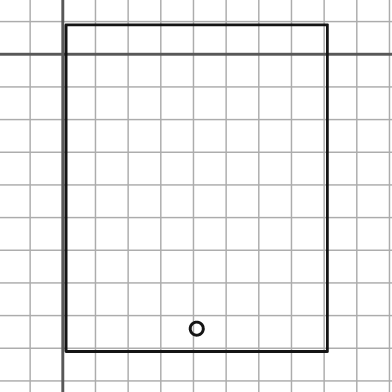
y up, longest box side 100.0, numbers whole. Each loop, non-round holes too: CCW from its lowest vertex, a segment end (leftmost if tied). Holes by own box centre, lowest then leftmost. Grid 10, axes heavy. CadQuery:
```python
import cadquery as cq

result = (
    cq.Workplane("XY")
    .moveTo(1.0, -91.0)
    .lineTo(81.0, -91.0)
    .lineTo(81.0, 9.0)
    .lineTo(1.0, 9.0)
    .close()
    .moveTo(41.0, -84.0)
    .circle(2.0)
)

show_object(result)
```